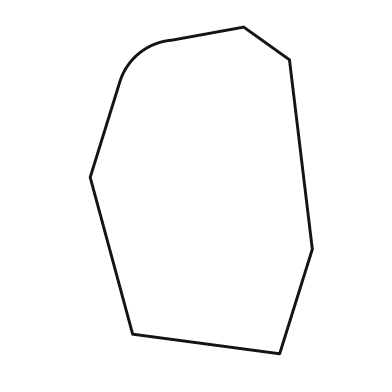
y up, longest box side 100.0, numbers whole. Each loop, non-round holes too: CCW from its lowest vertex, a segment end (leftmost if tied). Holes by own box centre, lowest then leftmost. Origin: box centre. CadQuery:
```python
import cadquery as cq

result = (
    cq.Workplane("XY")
    .moveTo(24.0, -50.0)
    .lineTo(34.0, -18.0)
    .lineTo(27.0, 40.0)
    .lineTo(13.0, 50.0)
    .lineTo(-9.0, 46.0)
    .threePointArc((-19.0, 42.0), (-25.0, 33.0))
    .lineTo(-34.0, 4.0)
    .lineTo(-21.0, -44.0)
    .close()
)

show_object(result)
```